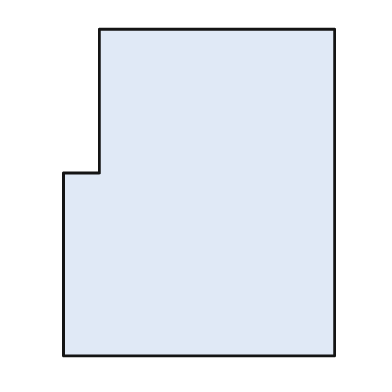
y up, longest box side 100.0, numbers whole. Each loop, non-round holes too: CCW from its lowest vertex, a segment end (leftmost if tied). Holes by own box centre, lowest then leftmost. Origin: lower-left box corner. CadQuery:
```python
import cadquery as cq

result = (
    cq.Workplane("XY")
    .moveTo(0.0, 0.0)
    .lineTo(83.0, 0.0)
    .lineTo(83.0, 100.0)
    .lineTo(11.0, 100.0)
    .lineTo(11.0, 56.0)
    .lineTo(0.0, 56.0)
    .close()
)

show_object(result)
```